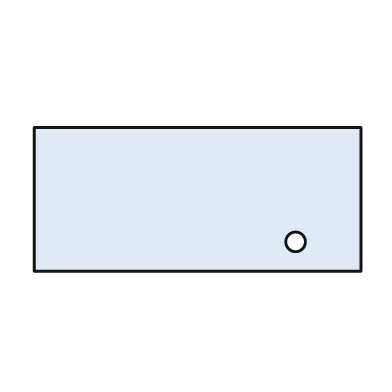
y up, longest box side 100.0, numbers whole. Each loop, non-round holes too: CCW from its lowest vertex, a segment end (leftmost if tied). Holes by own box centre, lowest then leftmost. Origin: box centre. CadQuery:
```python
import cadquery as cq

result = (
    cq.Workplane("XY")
    .moveTo(-50.0, -22.0)
    .lineTo(50.0, -22.0)
    .lineTo(50.0, 22.0)
    .lineTo(-50.0, 22.0)
    .close()
    .moveTo(30.0, -13.0)
    .circle(3.0)
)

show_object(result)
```